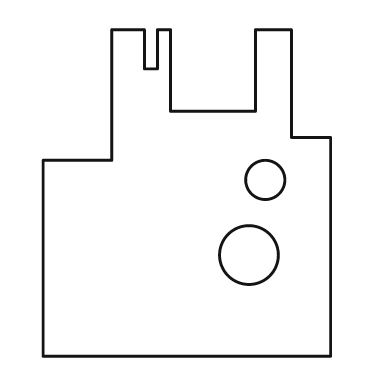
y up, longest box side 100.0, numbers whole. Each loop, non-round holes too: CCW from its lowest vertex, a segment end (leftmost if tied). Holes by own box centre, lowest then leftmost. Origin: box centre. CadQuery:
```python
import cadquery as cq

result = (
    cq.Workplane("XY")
    .moveTo(-44.0, -50.0)
    .lineTo(44.0, -50.0)
    .lineTo(44.0, 17.0)
    .lineTo(32.0, 17.0)
    .lineTo(32.0, 50.0)
    .lineTo(21.0, 50.0)
    .lineTo(21.0, 25.0)
    .lineTo(-5.0, 25.0)
    .lineTo(-5.0, 50.0)
    .lineTo(-9.0, 50.0)
    .lineTo(-9.0, 38.0)
    .lineTo(-13.0, 38.0)
    .lineTo(-13.0, 50.0)
    .lineTo(-23.0, 50.0)
    .lineTo(-23.0, 10.0)
    .lineTo(-44.0, 10.0)
    .close()
    .moveTo(19.0, -19.0)
    .circle(9.0)
    .moveTo(24.0, 4.0)
    .circle(6.0)
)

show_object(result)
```